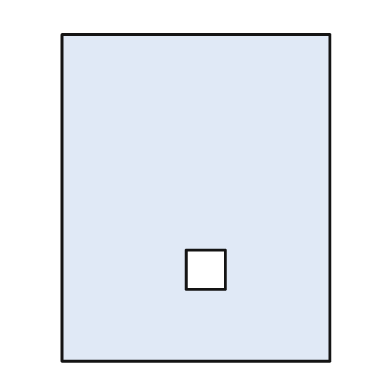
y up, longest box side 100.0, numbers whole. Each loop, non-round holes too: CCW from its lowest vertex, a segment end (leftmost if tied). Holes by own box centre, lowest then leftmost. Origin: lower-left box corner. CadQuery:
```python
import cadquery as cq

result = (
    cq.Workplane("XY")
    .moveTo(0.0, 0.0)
    .lineTo(82.0, 0.0)
    .lineTo(82.0, 100.0)
    .lineTo(0.0, 100.0)
    .close()
    .moveTo(38.0, 22.0)
    .lineTo(50.0, 22.0)
    .lineTo(50.0, 34.0)
    .lineTo(38.0, 34.0)
    .close()
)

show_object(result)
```